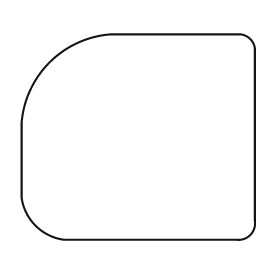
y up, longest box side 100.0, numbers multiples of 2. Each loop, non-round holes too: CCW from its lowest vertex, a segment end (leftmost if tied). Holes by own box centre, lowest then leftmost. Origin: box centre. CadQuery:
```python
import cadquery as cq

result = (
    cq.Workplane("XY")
    .moveTo(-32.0, -44.0)
    .lineTo(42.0, -44.0)
    .threePointArc((48.0, -42.0), (50.0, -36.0))
    .lineTo(50.0, 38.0)
    .threePointArc((48.0, 42.0), (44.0, 44.0))
    .lineTo(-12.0, 44.0)
    .threePointArc((-38.0, 32.0), (-50.0, 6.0))
    .lineTo(-50.0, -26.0)
    .threePointArc((-44.0, -38.0), (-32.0, -44.0))
    .close()
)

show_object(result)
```